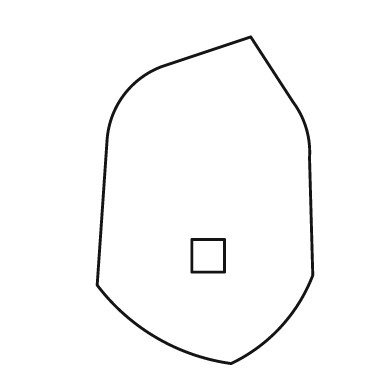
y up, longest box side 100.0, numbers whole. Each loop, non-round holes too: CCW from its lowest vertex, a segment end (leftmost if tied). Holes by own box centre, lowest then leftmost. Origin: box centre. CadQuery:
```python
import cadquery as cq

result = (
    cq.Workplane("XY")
    .moveTo(8.0, -50.0)
    .threePointArc((23.0, -39.0), (33.0, -23.0))
    .lineTo(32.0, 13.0)
    .threePointArc((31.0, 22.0), (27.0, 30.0))
    .lineTo(14.0, 50.0)
    .lineTo(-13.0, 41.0)
    .threePointArc((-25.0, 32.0), (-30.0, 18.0))
    .lineTo(-33.0, -26.0)
    .threePointArc((-15.0, -42.0), (8.0, -50.0))
    .close()
    .moveTo(-4.0, -22.0)
    .lineTo(6.0, -22.0)
    .lineTo(6.0, -12.0)
    .lineTo(-4.0, -12.0)
    .close()
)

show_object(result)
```